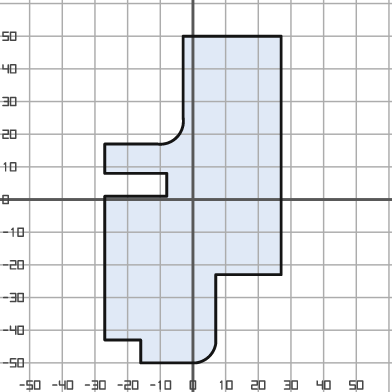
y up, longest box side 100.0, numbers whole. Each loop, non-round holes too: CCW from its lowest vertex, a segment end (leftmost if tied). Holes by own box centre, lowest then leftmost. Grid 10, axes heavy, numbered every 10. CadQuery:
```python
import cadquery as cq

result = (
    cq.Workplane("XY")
    .moveTo(-16.0, -50.0)
    .lineTo(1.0, -50.0)
    .threePointArc((5.0, -48.0), (7.0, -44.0))
    .lineTo(7.0, -23.0)
    .lineTo(27.0, -23.0)
    .lineTo(27.0, 50.0)
    .lineTo(-3.0, 50.0)
    .lineTo(-3.0, 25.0)
    .threePointArc((-5.0, 19.0), (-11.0, 17.0))
    .lineTo(-27.0, 17.0)
    .lineTo(-27.0, 8.0)
    .lineTo(-8.0, 8.0)
    .lineTo(-8.0, 1.0)
    .lineTo(-27.0, 1.0)
    .lineTo(-27.0, -43.0)
    .lineTo(-16.0, -43.0)
    .close()
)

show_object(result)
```